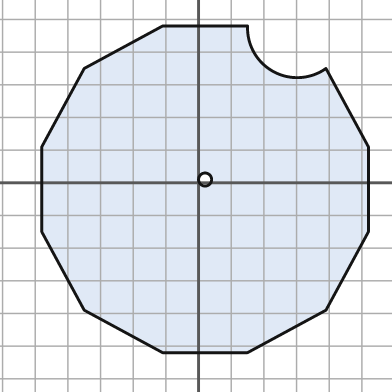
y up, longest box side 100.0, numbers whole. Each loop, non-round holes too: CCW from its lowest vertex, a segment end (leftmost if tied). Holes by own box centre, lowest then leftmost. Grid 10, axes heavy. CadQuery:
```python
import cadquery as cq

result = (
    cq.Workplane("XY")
    .moveTo(-11.0, -52.0)
    .lineTo(15.0, -52.0)
    .lineTo(39.0, -39.0)
    .lineTo(52.0, -15.0)
    .lineTo(52.0, 11.0)
    .lineTo(39.0, 35.0)
    .threePointArc((23.0, 34.0), (15.0, 48.0))
    .lineTo(-11.0, 48.0)
    .lineTo(-35.0, 35.0)
    .lineTo(-48.0, 11.0)
    .lineTo(-48.0, -15.0)
    .lineTo(-35.0, -39.0)
    .close()
    .moveTo(2.0, 1.0)
    .circle(2.0)
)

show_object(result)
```